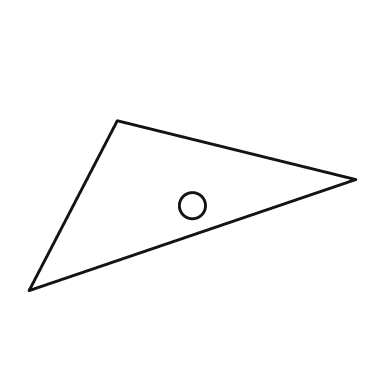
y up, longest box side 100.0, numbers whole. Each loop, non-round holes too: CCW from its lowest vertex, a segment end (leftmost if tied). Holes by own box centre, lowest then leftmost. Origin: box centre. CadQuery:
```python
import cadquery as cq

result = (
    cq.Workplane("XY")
    .moveTo(-50.0, -26.0)
    .lineTo(50.0, 8.0)
    .lineTo(-23.0, 26.0)
    .close()
    .moveTo(0.0, 0.0)
    .circle(4.0)
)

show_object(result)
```